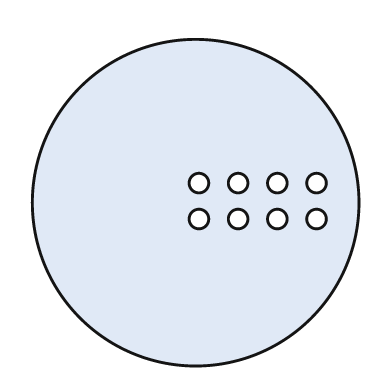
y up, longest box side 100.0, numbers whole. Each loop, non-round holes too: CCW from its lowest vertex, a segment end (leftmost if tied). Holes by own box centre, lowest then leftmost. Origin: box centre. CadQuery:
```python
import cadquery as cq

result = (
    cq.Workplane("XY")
    .moveTo(0.0, 0.0)
    .circle(50.0)
    .moveTo(1.0, -5.0)
    .circle(3.0)
    .moveTo(13.0, -5.0)
    .circle(3.0)
    .moveTo(25.0, -5.0)
    .circle(3.0)
    .moveTo(37.0, -5.0)
    .circle(3.0)
    .moveTo(1.0, 6.0)
    .circle(3.0)
    .moveTo(13.0, 6.0)
    .circle(3.0)
    .moveTo(25.0, 6.0)
    .circle(3.0)
    .moveTo(37.0, 6.0)
    .circle(3.0)
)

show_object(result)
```